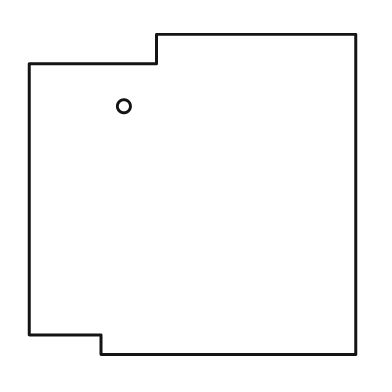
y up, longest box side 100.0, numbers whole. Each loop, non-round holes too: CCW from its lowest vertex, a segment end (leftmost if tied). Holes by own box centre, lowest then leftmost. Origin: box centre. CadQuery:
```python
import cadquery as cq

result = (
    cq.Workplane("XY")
    .moveTo(-28.0, -49.0)
    .lineTo(50.0, -49.0)
    .lineTo(50.0, 49.0)
    .lineTo(-11.0, 49.0)
    .lineTo(-11.0, 40.0)
    .lineTo(-50.0, 40.0)
    .lineTo(-50.0, -43.0)
    .lineTo(-28.0, -43.0)
    .close()
    .moveTo(-21.0, 27.0)
    .circle(2.0)
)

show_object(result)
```